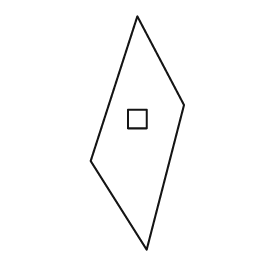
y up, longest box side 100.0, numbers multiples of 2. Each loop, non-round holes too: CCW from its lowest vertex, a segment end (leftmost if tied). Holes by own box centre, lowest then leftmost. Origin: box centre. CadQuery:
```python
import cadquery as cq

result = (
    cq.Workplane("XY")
    .moveTo(4.0, -50.0)
    .lineTo(20.0, 12.0)
    .lineTo(0.0, 50.0)
    .lineTo(-20.0, -12.0)
    .close()
    .moveTo(-4.0, 2.0)
    .lineTo(4.0, 2.0)
    .lineTo(4.0, 10.0)
    .lineTo(-4.0, 10.0)
    .close()
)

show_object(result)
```